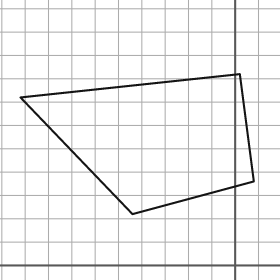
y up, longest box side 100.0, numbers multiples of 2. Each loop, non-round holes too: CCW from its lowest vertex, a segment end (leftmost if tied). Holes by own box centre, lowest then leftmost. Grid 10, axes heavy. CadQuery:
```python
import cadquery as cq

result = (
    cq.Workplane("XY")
    .moveTo(-44.0, 22.0)
    .lineTo(8.0, 36.0)
    .lineTo(2.0, 82.0)
    .lineTo(-92.0, 72.0)
    .close()
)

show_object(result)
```